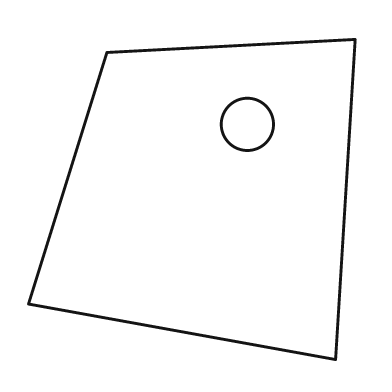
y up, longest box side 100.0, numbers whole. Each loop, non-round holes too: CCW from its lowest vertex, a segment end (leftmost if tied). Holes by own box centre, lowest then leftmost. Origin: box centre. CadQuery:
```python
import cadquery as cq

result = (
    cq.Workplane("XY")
    .moveTo(44.0, -49.0)
    .lineTo(50.0, 49.0)
    .lineTo(-26.0, 45.0)
    .lineTo(-50.0, -32.0)
    .close()
    .moveTo(17.0, 23.0)
    .circle(8.0)
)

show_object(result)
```